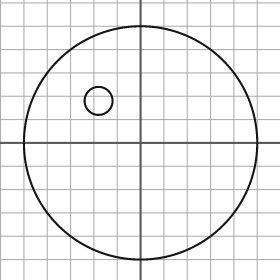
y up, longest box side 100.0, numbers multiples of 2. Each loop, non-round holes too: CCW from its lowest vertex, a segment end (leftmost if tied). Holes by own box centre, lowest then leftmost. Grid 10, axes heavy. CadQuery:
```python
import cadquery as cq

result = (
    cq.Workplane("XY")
    .moveTo(0.0, 0.0)
    .circle(50.0)
    .moveTo(-18.0, 18.0)
    .circle(6.0)
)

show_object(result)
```